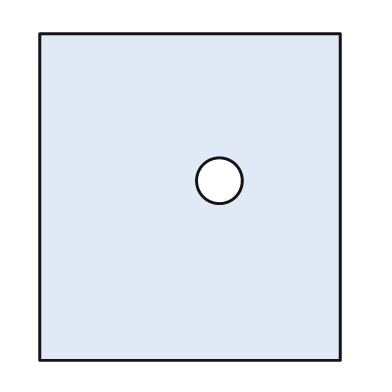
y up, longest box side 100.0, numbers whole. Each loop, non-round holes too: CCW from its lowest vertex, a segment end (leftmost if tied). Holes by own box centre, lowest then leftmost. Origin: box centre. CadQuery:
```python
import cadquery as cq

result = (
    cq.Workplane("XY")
    .moveTo(-46.0, -50.0)
    .lineTo(46.0, -50.0)
    .lineTo(46.0, 50.0)
    .lineTo(-46.0, 50.0)
    .close()
    .moveTo(9.0, 5.0)
    .circle(7.0)
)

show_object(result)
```